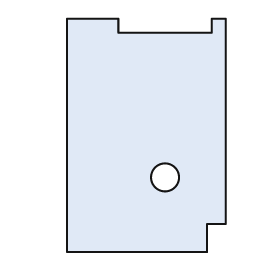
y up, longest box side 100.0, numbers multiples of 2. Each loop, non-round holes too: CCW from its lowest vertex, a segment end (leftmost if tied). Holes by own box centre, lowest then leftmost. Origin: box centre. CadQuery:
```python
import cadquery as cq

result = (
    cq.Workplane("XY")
    .moveTo(-34.0, -50.0)
    .lineTo(26.0, -50.0)
    .lineTo(26.0, -38.0)
    .lineTo(34.0, -38.0)
    .lineTo(34.0, 50.0)
    .lineTo(28.0, 50.0)
    .lineTo(28.0, 44.0)
    .lineTo(-12.0, 44.0)
    .lineTo(-12.0, 50.0)
    .lineTo(-34.0, 50.0)
    .close()
    .moveTo(8.0, -18.0)
    .circle(6.0)
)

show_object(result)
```